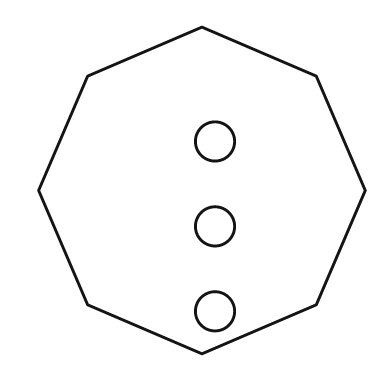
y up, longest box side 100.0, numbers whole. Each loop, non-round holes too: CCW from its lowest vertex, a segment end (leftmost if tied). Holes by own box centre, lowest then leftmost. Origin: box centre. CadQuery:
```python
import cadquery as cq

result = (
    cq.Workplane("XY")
    .moveTo(0.0, -50.0)
    .lineTo(35.0, -35.0)
    .lineTo(50.0, 0.0)
    .lineTo(35.0, 35.0)
    .lineTo(0.0, 50.0)
    .lineTo(-35.0, 35.0)
    .lineTo(-50.0, 0.0)
    .lineTo(-35.0, -35.0)
    .close()
    .moveTo(4.0, -37.0)
    .circle(6.0)
    .moveTo(4.0, -11.0)
    .circle(6.0)
    .moveTo(4.0, 15.0)
    .circle(6.0)
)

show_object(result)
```